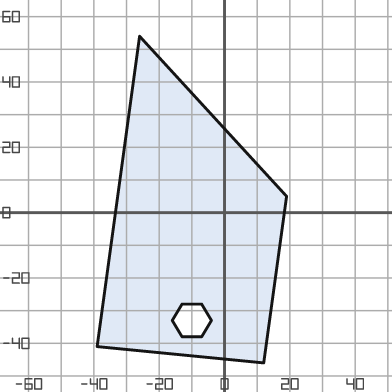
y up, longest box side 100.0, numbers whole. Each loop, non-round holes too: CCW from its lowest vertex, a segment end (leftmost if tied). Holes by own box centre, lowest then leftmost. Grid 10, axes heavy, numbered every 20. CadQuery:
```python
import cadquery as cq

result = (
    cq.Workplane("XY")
    .moveTo(12.0, -46.0)
    .lineTo(19.0, 5.0)
    .lineTo(-26.0, 54.0)
    .lineTo(-39.0, -41.0)
    .close()
    .moveTo(-13.0, -38.0)
    .lineTo(-7.0, -38.0)
    .lineTo(-4.0, -33.0)
    .lineTo(-7.0, -28.0)
    .lineTo(-13.0, -28.0)
    .lineTo(-16.0, -33.0)
    .close()
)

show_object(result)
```